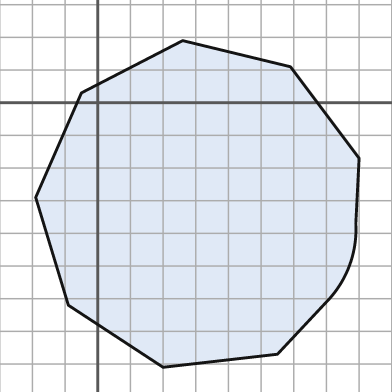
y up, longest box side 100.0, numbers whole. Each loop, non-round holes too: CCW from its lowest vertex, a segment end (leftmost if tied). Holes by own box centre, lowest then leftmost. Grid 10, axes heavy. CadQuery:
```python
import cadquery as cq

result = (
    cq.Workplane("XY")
    .moveTo(20.0, -81.0)
    .lineTo(55.0, -77.0)
    .lineTo(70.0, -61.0)
    .threePointArc((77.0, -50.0), (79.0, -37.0))
    .lineTo(80.0, -17.0)
    .lineTo(59.0, 11.0)
    .lineTo(26.0, 19.0)
    .lineTo(-5.0, 3.0)
    .lineTo(-19.0, -29.0)
    .lineTo(-9.0, -62.0)
    .close()
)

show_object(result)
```